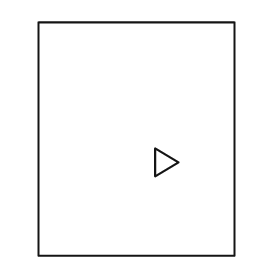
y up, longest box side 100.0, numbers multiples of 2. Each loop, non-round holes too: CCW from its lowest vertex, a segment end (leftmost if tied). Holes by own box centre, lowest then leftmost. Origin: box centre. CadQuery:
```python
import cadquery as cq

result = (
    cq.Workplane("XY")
    .moveTo(-42.0, -50.0)
    .lineTo(42.0, -50.0)
    .lineTo(42.0, 50.0)
    .lineTo(-42.0, 50.0)
    .close()
    .moveTo(8.0, -16.0)
    .lineTo(18.0, -10.0)
    .lineTo(8.0, -4.0)
    .close()
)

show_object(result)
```